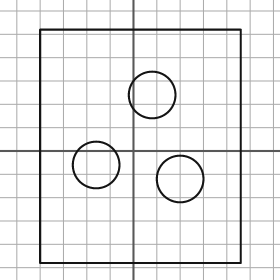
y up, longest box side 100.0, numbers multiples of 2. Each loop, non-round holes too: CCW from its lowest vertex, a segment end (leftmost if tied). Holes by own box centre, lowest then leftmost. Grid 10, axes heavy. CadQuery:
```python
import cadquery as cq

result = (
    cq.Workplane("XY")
    .moveTo(-40.0, -48.0)
    .lineTo(46.0, -48.0)
    .lineTo(46.0, 52.0)
    .lineTo(-40.0, 52.0)
    .close()
    .moveTo(20.0, -12.0)
    .circle(10.0)
    .moveTo(-16.0, -6.0)
    .circle(10.0)
    .moveTo(8.0, 24.0)
    .circle(10.0)
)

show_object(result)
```